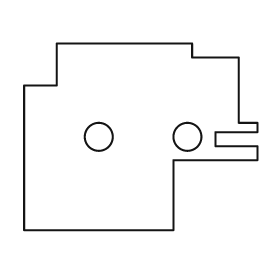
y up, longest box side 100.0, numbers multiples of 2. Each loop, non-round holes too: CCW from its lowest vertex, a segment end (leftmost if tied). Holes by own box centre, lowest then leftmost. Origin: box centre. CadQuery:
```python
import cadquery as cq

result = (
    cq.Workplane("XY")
    .moveTo(-50.0, -40.0)
    .lineTo(14.0, -40.0)
    .lineTo(14.0, -10.0)
    .lineTo(50.0, -10.0)
    .lineTo(50.0, -4.0)
    .lineTo(32.0, -4.0)
    .lineTo(32.0, 2.0)
    .lineTo(50.0, 2.0)
    .lineTo(50.0, 6.0)
    .lineTo(42.0, 6.0)
    .lineTo(42.0, 34.0)
    .lineTo(22.0, 34.0)
    .lineTo(22.0, 40.0)
    .lineTo(-36.0, 40.0)
    .lineTo(-36.0, 22.0)
    .lineTo(-50.0, 22.0)
    .close()
    .moveTo(-18.0, 0.0)
    .circle(6.0)
    .moveTo(20.0, 0.0)
    .circle(6.0)
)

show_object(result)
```